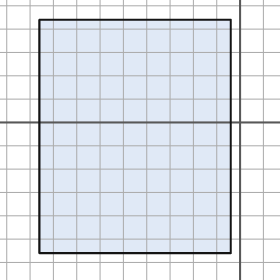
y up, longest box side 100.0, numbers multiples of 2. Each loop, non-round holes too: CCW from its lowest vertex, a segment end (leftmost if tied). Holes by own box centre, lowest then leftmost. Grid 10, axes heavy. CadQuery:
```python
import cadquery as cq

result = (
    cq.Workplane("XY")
    .moveTo(-86.0, -56.0)
    .lineTo(-4.0, -56.0)
    .lineTo(-4.0, 44.0)
    .lineTo(-86.0, 44.0)
    .close()
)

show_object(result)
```